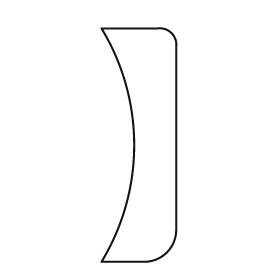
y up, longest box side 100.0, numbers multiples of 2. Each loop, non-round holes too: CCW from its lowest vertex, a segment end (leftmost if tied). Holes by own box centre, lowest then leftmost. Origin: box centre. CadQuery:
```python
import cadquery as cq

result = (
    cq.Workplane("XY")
    .moveTo(-16.0, -50.0)
    .lineTo(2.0, -50.0)
    .threePointArc((12.0, -46.0), (16.0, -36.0))
    .lineTo(16.0, 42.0)
    .threePointArc((14.0, 48.0), (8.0, 50.0))
    .lineTo(-16.0, 50.0)
    .threePointArc((-2.0, 0.0), (-16.0, -50.0))
    .close()
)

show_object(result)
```